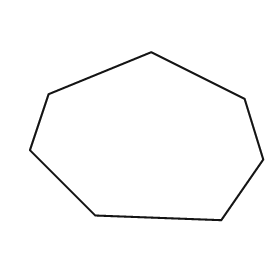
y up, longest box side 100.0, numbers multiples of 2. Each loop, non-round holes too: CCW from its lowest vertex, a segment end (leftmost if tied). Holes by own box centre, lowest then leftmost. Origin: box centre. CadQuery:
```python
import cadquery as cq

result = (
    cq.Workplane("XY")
    .moveTo(32.0, -36.0)
    .lineTo(50.0, -10.0)
    .lineTo(42.0, 16.0)
    .lineTo(2.0, 36.0)
    .lineTo(-42.0, 18.0)
    .lineTo(-50.0, -6.0)
    .lineTo(-22.0, -34.0)
    .close()
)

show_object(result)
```